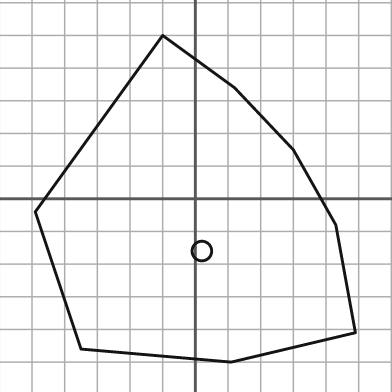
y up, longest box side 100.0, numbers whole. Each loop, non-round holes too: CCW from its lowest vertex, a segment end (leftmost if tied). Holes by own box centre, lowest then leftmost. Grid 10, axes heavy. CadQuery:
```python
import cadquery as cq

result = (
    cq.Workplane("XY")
    .moveTo(11.0, -50.0)
    .lineTo(49.0, -41.0)
    .lineTo(43.0, -8.0)
    .lineTo(30.0, 15.0)
    .lineTo(12.0, 34.0)
    .lineTo(-10.0, 50.0)
    .lineTo(-49.0, -4.0)
    .lineTo(-35.0, -46.0)
    .close()
    .moveTo(2.0, -16.0)
    .circle(3.0)
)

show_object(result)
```